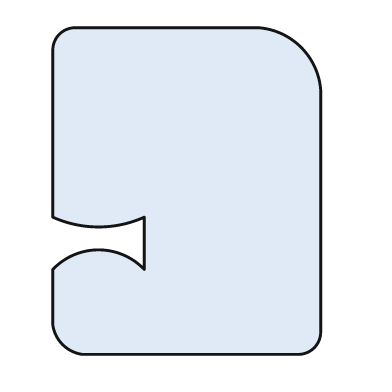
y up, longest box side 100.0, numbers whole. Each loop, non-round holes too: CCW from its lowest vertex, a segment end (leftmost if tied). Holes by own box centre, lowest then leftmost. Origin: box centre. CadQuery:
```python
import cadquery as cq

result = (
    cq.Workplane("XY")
    .moveTo(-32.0, -50.0)
    .lineTo(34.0, -50.0)
    .threePointArc((39.0, -48.0), (41.0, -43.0))
    .lineTo(41.0, 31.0)
    .threePointArc((35.0, 44.0), (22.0, 50.0))
    .lineTo(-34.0, 50.0)
    .threePointArc((-39.0, 48.0), (-41.0, 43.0))
    .lineTo(-41.0, -8.0)
    .threePointArc((-27.0, -11.0), (-13.0, -8.0))
    .lineTo(-13.0, -24.0)
    .threePointArc((-27.0, -18.0), (-41.0, -24.0))
    .lineTo(-41.0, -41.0)
    .threePointArc((-38.0, -47.0), (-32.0, -50.0))
    .close()
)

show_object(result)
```